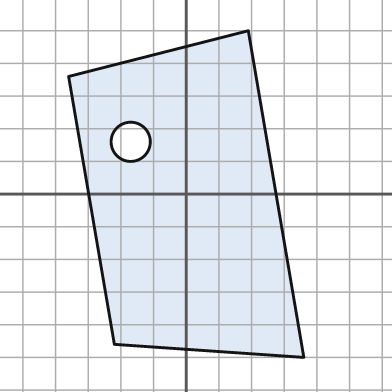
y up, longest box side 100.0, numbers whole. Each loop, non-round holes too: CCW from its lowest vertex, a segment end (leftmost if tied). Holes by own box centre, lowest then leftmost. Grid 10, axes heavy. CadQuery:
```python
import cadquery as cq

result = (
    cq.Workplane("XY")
    .moveTo(36.0, -50.0)
    .lineTo(19.0, 50.0)
    .lineTo(-36.0, 36.0)
    .lineTo(-22.0, -46.0)
    .close()
    .moveTo(-17.0, 16.0)
    .circle(6.0)
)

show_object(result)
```